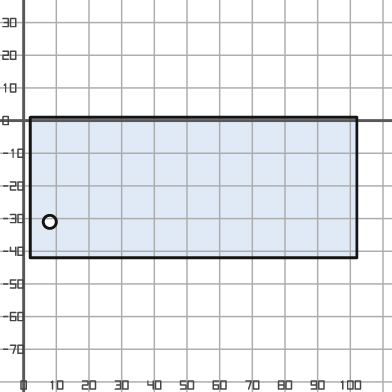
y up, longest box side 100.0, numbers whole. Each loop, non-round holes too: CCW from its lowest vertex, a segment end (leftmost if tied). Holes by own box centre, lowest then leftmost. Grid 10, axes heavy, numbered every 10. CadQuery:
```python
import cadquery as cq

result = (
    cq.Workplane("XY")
    .moveTo(2.0, -42.0)
    .lineTo(102.0, -42.0)
    .lineTo(102.0, 1.0)
    .lineTo(2.0, 1.0)
    .close()
    .moveTo(8.0, -31.0)
    .circle(2.0)
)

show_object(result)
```